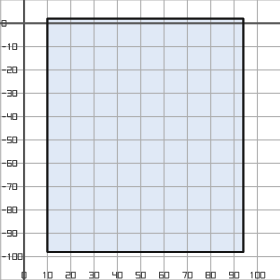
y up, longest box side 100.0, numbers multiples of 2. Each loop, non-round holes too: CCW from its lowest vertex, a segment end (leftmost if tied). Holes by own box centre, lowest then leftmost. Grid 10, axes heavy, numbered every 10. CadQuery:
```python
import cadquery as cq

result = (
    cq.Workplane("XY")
    .moveTo(10.0, -98.0)
    .lineTo(94.0, -98.0)
    .lineTo(94.0, 2.0)
    .lineTo(10.0, 2.0)
    .close()
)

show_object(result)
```